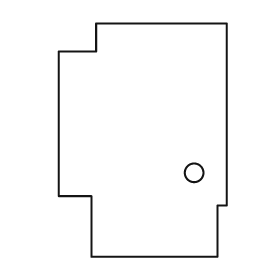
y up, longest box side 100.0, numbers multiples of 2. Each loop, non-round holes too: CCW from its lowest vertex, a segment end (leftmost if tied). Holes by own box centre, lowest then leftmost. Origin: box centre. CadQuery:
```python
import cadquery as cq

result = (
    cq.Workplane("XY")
    .moveTo(-22.0, -50.0)
    .lineTo(32.0, -50.0)
    .lineTo(32.0, -28.0)
    .lineTo(36.0, -28.0)
    .lineTo(36.0, 50.0)
    .lineTo(-20.0, 50.0)
    .lineTo(-20.0, 38.0)
    .lineTo(-36.0, 38.0)
    .lineTo(-36.0, -24.0)
    .lineTo(-22.0, -24.0)
    .close()
    .moveTo(22.0, -14.0)
    .circle(4.0)
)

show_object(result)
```